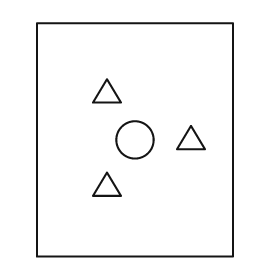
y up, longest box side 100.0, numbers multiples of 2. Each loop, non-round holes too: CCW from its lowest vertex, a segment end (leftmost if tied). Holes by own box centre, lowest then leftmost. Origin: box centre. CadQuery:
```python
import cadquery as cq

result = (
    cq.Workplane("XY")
    .moveTo(-42.0, -50.0)
    .lineTo(42.0, -50.0)
    .lineTo(42.0, 50.0)
    .lineTo(-42.0, 50.0)
    .close()
    .moveTo(-18.0, -24.0)
    .lineTo(-6.0, -24.0)
    .lineTo(-12.0, -14.0)
    .close()
    .moveTo(0.0, 0.0)
    .circle(8.0)
    .moveTo(18.0, -4.0)
    .lineTo(30.0, -4.0)
    .lineTo(24.0, 6.0)
    .close()
    .moveTo(-18.0, 16.0)
    .lineTo(-6.0, 16.0)
    .lineTo(-12.0, 26.0)
    .close()
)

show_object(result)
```